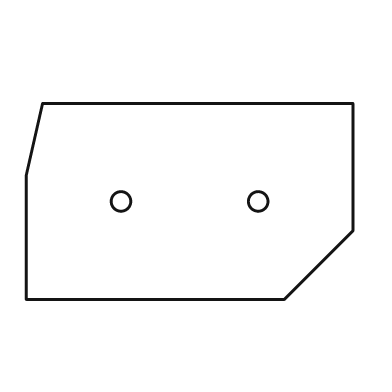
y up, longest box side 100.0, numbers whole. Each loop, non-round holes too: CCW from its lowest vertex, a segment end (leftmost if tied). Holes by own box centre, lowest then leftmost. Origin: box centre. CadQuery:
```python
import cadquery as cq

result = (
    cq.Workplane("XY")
    .moveTo(-50.0, -30.0)
    .lineTo(29.0, -30.0)
    .lineTo(50.0, -9.0)
    .lineTo(50.0, 30.0)
    .lineTo(-45.0, 30.0)
    .lineTo(-50.0, 8.0)
    .close()
    .moveTo(-21.0, 0.0)
    .circle(3.0)
    .moveTo(21.0, 0.0)
    .circle(3.0)
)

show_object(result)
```